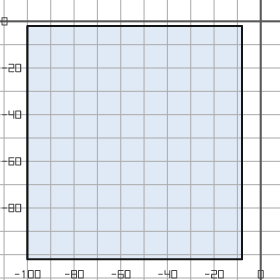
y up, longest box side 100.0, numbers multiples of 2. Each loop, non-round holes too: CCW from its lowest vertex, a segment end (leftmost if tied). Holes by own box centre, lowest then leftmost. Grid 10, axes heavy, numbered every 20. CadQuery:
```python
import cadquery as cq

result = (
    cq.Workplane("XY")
    .moveTo(-100.0, -102.0)
    .lineTo(-8.0, -102.0)
    .lineTo(-8.0, -2.0)
    .lineTo(-100.0, -2.0)
    .close()
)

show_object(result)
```